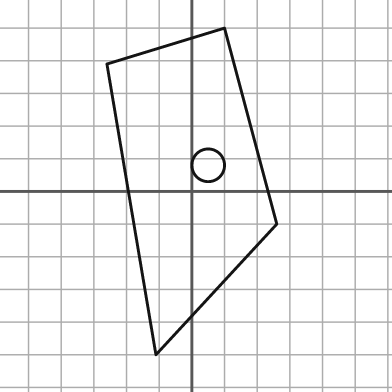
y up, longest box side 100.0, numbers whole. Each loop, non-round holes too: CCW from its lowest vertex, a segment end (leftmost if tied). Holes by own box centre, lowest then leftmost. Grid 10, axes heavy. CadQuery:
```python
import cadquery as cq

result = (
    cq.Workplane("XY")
    .moveTo(-11.0, -50.0)
    .lineTo(26.0, -10.0)
    .lineTo(10.0, 50.0)
    .lineTo(-26.0, 39.0)
    .close()
    .moveTo(5.0, 8.0)
    .circle(5.0)
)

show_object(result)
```